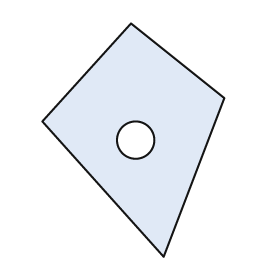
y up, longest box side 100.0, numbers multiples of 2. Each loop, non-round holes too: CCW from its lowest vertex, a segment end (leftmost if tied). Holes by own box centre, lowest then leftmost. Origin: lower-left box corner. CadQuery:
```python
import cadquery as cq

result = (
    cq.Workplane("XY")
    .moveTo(52.0, 0.0)
    .lineTo(78.0, 68.0)
    .lineTo(38.0, 100.0)
    .lineTo(0.0, 58.0)
    .close()
    .moveTo(40.0, 50.0)
    .circle(8.0)
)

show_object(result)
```